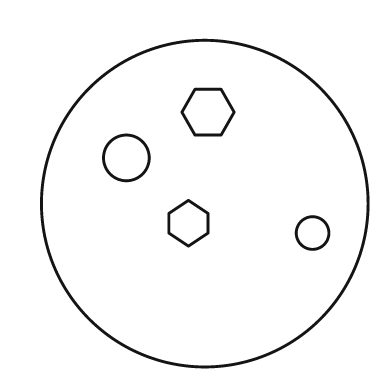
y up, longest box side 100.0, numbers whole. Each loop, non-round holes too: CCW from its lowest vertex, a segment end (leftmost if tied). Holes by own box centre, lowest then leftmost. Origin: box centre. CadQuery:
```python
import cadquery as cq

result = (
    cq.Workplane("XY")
    .moveTo(0.0, 0.0)
    .circle(50.0)
    .moveTo(33.0, -9.0)
    .circle(5.0)
    .moveTo(-5.0, -13.0)
    .lineTo(1.0, -9.0)
    .lineTo(1.0, -3.0)
    .lineTo(-5.0, 1.0)
    .lineTo(-11.0, -3.0)
    .lineTo(-11.0, -9.0)
    .close()
    .moveTo(-24.0, 14.0)
    .circle(7.0)
    .moveTo(-3.0, 21.0)
    .lineTo(5.0, 21.0)
    .lineTo(9.0, 28.0)
    .lineTo(5.0, 35.0)
    .lineTo(-3.0, 35.0)
    .lineTo(-7.0, 28.0)
    .close()
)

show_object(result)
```